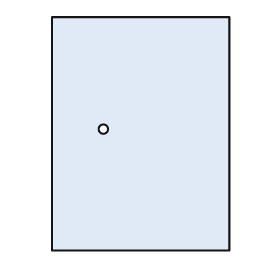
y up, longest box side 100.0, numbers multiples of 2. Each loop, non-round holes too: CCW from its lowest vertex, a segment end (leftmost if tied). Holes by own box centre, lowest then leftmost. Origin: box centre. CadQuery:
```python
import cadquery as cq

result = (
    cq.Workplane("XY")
    .moveTo(-38.0, -50.0)
    .lineTo(38.0, -50.0)
    .lineTo(38.0, 50.0)
    .lineTo(-38.0, 50.0)
    .close()
    .moveTo(-16.0, 2.0)
    .circle(2.0)
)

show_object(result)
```